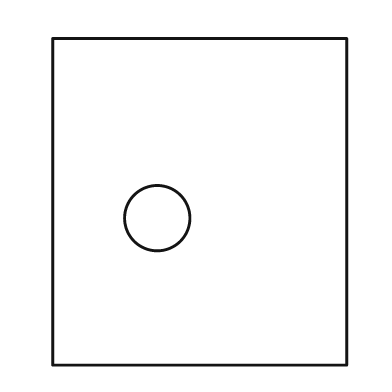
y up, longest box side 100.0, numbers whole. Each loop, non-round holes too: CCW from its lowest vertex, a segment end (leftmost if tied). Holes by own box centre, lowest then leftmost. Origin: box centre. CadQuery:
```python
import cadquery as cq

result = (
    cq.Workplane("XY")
    .moveTo(-45.0, -50.0)
    .lineTo(45.0, -50.0)
    .lineTo(45.0, 50.0)
    .lineTo(-45.0, 50.0)
    .close()
    .moveTo(-13.0, -5.0)
    .circle(10.0)
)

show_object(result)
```